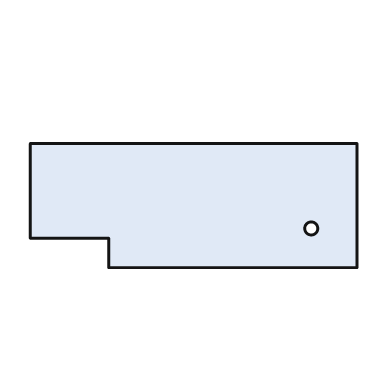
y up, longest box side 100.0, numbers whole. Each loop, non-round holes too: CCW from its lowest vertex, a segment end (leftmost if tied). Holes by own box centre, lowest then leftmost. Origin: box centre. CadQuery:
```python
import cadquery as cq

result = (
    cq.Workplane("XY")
    .moveTo(-26.0, -19.0)
    .lineTo(50.0, -19.0)
    .lineTo(50.0, 19.0)
    .lineTo(-50.0, 19.0)
    .lineTo(-50.0, -10.0)
    .lineTo(-26.0, -10.0)
    .close()
    .moveTo(36.0, -7.0)
    .circle(2.0)
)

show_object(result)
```